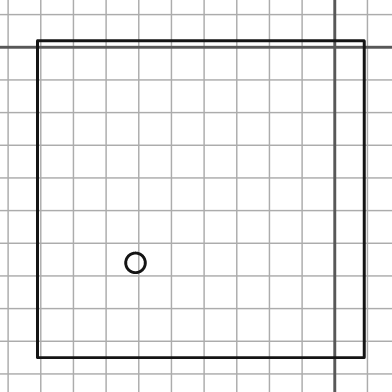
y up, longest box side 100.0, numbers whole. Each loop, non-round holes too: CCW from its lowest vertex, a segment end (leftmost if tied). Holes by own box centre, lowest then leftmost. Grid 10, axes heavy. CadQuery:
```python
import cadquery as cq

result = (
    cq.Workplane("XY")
    .moveTo(-91.0, -95.0)
    .lineTo(9.0, -95.0)
    .lineTo(9.0, 2.0)
    .lineTo(-91.0, 2.0)
    .close()
    .moveTo(-61.0, -66.0)
    .circle(3.0)
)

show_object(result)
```